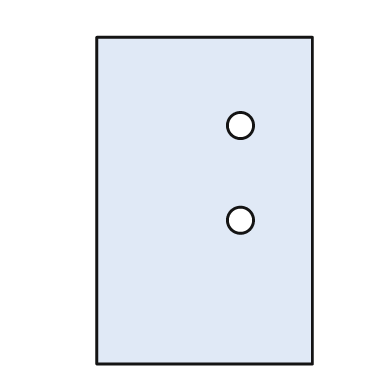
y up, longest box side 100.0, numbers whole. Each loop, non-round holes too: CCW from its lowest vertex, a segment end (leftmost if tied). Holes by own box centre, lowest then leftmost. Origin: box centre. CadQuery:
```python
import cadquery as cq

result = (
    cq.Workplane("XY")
    .moveTo(-33.0, -50.0)
    .lineTo(33.0, -50.0)
    .lineTo(33.0, 50.0)
    .lineTo(-33.0, 50.0)
    .close()
    .moveTo(11.0, -6.0)
    .circle(4.0)
    .moveTo(11.0, 23.0)
    .circle(4.0)
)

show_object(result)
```